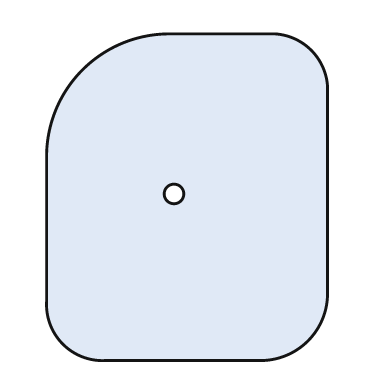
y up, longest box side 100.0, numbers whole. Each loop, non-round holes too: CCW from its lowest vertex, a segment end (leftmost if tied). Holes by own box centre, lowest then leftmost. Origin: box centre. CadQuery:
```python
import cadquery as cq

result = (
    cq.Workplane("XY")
    .moveTo(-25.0, -50.0)
    .lineTo(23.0, -50.0)
    .threePointArc((37.0, -44.0), (43.0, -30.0))
    .lineTo(43.0, 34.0)
    .threePointArc((38.0, 45.0), (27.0, 50.0))
    .lineTo(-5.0, 50.0)
    .threePointArc((-32.0, 39.0), (-43.0, 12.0))
    .lineTo(-43.0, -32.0)
    .threePointArc((-38.0, -45.0), (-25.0, -50.0))
    .close()
    .moveTo(-4.0, 1.0)
    .circle(3.0)
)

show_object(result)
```